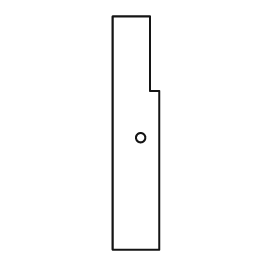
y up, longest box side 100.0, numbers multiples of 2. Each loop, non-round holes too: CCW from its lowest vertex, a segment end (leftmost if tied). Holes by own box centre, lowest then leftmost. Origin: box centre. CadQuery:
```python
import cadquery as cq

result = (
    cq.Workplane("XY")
    .moveTo(-10.0, -50.0)
    .lineTo(10.0, -50.0)
    .lineTo(10.0, 18.0)
    .lineTo(6.0, 18.0)
    .lineTo(6.0, 50.0)
    .lineTo(-10.0, 50.0)
    .close()
    .moveTo(2.0, -2.0)
    .circle(2.0)
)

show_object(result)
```